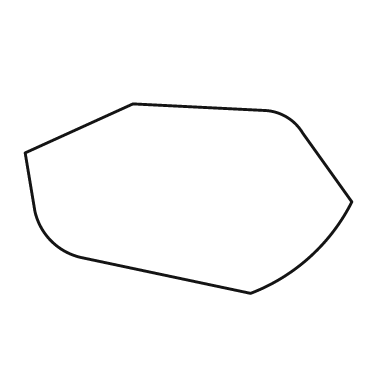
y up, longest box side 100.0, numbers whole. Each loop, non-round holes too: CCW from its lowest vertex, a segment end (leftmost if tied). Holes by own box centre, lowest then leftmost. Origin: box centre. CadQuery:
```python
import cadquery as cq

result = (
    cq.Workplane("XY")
    .moveTo(19.0, -29.0)
    .threePointArc((37.0, -18.0), (50.0, -1.0))
    .lineTo(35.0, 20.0)
    .threePointArc((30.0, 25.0), (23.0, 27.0))
    .lineTo(-17.0, 29.0)
    .lineTo(-50.0, 14.0)
    .lineTo(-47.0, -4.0)
    .threePointArc((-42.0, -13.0), (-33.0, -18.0))
    .close()
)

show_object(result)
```